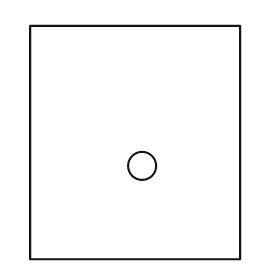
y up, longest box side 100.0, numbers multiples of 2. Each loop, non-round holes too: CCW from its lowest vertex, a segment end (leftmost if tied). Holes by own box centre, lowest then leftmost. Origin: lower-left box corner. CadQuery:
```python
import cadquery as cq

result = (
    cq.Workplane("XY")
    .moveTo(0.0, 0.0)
    .lineTo(90.0, 0.0)
    .lineTo(90.0, 100.0)
    .lineTo(0.0, 100.0)
    .close()
    .moveTo(48.0, 40.0)
    .circle(6.0)
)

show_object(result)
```